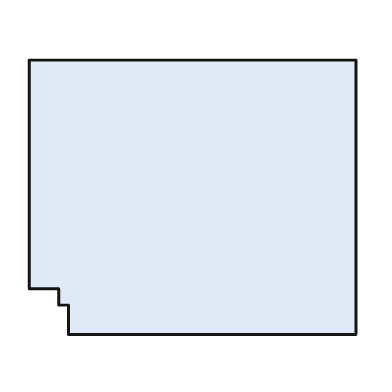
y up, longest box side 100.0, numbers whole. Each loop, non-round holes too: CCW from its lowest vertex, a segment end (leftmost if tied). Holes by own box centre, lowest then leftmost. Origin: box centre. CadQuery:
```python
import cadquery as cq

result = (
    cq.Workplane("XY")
    .moveTo(-38.0, -42.0)
    .lineTo(50.0, -42.0)
    .lineTo(50.0, 42.0)
    .lineTo(-50.0, 42.0)
    .lineTo(-50.0, -28.0)
    .lineTo(-41.0, -28.0)
    .lineTo(-41.0, -33.0)
    .lineTo(-38.0, -33.0)
    .close()
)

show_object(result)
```